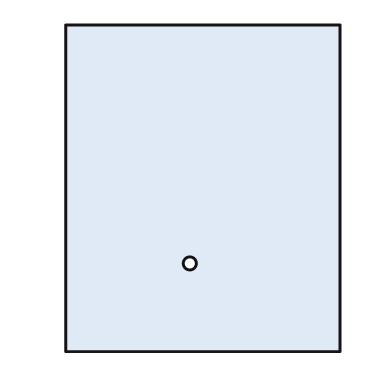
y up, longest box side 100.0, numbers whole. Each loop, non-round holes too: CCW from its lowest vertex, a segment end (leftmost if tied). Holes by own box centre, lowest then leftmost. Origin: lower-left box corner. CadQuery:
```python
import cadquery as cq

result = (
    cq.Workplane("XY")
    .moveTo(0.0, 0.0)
    .lineTo(84.0, 0.0)
    .lineTo(84.0, 100.0)
    .lineTo(0.0, 100.0)
    .close()
    .moveTo(38.0, 27.0)
    .circle(2.0)
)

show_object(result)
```